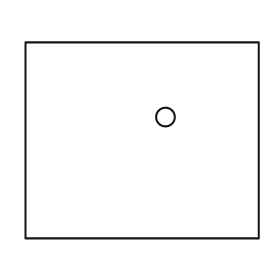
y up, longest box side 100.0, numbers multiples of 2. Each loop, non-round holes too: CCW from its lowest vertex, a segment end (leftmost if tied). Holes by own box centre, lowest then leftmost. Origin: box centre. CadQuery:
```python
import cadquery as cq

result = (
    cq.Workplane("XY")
    .moveTo(-50.0, -42.0)
    .lineTo(50.0, -42.0)
    .lineTo(50.0, 42.0)
    .lineTo(-50.0, 42.0)
    .close()
    .moveTo(10.0, 10.0)
    .circle(4.0)
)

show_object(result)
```